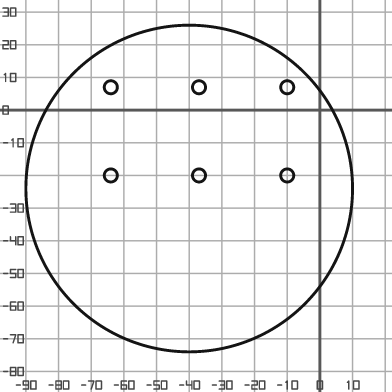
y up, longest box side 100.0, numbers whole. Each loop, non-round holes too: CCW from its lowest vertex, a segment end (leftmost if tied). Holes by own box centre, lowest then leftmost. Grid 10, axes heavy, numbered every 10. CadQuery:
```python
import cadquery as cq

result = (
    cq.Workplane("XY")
    .moveTo(-40.0, -24.0)
    .circle(50.0)
    .moveTo(-64.0, -20.0)
    .circle(2.0)
    .moveTo(-37.0, -20.0)
    .circle(2.0)
    .moveTo(-10.0, -20.0)
    .circle(2.0)
    .moveTo(-64.0, 7.0)
    .circle(2.0)
    .moveTo(-37.0, 7.0)
    .circle(2.0)
    .moveTo(-10.0, 7.0)
    .circle(2.0)
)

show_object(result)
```